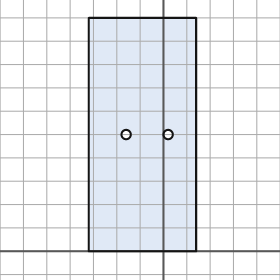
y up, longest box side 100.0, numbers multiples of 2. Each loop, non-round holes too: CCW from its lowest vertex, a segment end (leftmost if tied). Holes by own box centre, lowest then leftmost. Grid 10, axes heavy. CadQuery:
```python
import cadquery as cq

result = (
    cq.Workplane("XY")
    .moveTo(-32.0, 0.0)
    .lineTo(14.0, 0.0)
    .lineTo(14.0, 100.0)
    .lineTo(-32.0, 100.0)
    .close()
    .moveTo(-16.0, 50.0)
    .circle(2.0)
    .moveTo(2.0, 50.0)
    .circle(2.0)
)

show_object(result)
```